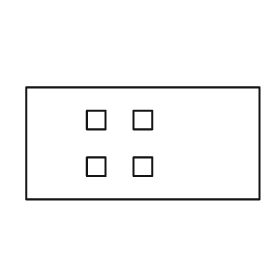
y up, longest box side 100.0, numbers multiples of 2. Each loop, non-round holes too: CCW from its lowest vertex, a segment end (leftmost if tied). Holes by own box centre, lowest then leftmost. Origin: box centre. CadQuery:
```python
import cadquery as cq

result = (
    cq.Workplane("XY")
    .moveTo(-50.0, -24.0)
    .lineTo(50.0, -24.0)
    .lineTo(50.0, 24.0)
    .lineTo(-50.0, 24.0)
    .close()
    .moveTo(-24.0, -14.0)
    .lineTo(-16.0, -14.0)
    .lineTo(-16.0, -6.0)
    .lineTo(-24.0, -6.0)
    .close()
    .moveTo(-4.0, -14.0)
    .lineTo(4.0, -14.0)
    .lineTo(4.0, -6.0)
    .lineTo(-4.0, -6.0)
    .close()
    .moveTo(-24.0, 6.0)
    .lineTo(-16.0, 6.0)
    .lineTo(-16.0, 14.0)
    .lineTo(-24.0, 14.0)
    .close()
    .moveTo(-4.0, 6.0)
    .lineTo(4.0, 6.0)
    .lineTo(4.0, 14.0)
    .lineTo(-4.0, 14.0)
    .close()
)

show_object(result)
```